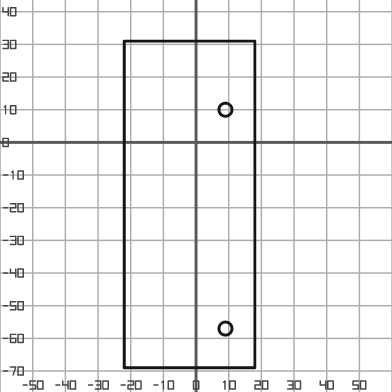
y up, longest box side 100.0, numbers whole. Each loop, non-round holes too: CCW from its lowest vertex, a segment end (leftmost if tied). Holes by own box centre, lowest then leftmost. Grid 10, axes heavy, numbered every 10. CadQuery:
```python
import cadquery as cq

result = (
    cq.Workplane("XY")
    .moveTo(-22.0, -69.0)
    .lineTo(18.0, -69.0)
    .lineTo(18.0, 31.0)
    .lineTo(-22.0, 31.0)
    .close()
    .moveTo(9.0, -57.0)
    .circle(2.0)
    .moveTo(9.0, 10.0)
    .circle(2.0)
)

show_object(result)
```